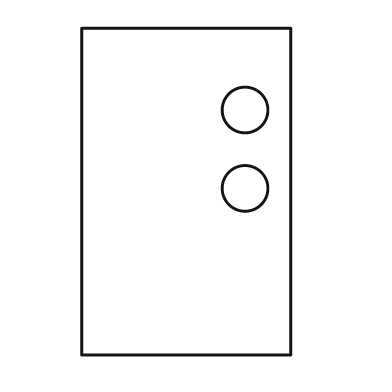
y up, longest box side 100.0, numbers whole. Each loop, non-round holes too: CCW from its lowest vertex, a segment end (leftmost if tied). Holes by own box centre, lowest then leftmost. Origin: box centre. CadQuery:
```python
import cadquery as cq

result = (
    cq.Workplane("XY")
    .moveTo(-32.0, -50.0)
    .lineTo(32.0, -50.0)
    .lineTo(32.0, 50.0)
    .lineTo(-32.0, 50.0)
    .close()
    .moveTo(18.0, 1.0)
    .circle(7.0)
    .moveTo(18.0, 25.0)
    .circle(7.0)
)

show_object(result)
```